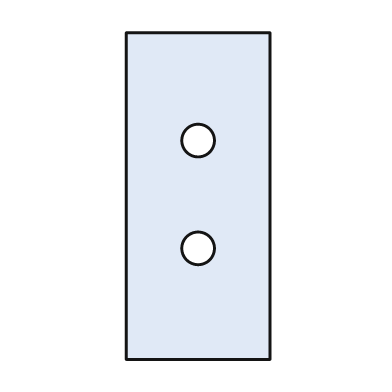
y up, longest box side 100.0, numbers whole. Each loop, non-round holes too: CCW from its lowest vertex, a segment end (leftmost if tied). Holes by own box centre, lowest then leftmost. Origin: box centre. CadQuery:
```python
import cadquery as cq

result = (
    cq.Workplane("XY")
    .moveTo(-22.0, -50.0)
    .lineTo(22.0, -50.0)
    .lineTo(22.0, 50.0)
    .lineTo(-22.0, 50.0)
    .close()
    .moveTo(0.0, -16.0)
    .circle(5.0)
    .moveTo(0.0, 17.0)
    .circle(5.0)
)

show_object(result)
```